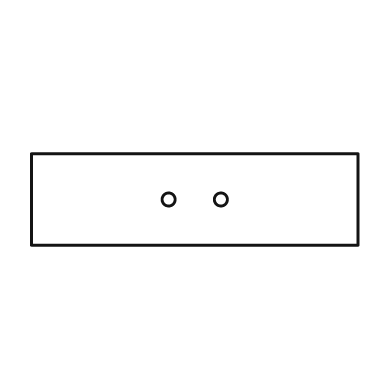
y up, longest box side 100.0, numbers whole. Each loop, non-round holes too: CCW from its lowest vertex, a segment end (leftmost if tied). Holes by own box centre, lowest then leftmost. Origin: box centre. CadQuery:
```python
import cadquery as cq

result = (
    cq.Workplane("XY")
    .moveTo(-50.0, -14.0)
    .lineTo(50.0, -14.0)
    .lineTo(50.0, 14.0)
    .lineTo(-50.0, 14.0)
    .close()
    .moveTo(-8.0, 0.0)
    .circle(2.0)
    .moveTo(8.0, 0.0)
    .circle(2.0)
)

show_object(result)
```